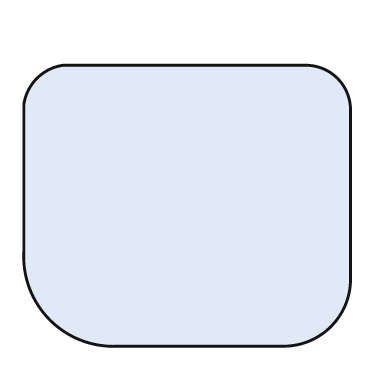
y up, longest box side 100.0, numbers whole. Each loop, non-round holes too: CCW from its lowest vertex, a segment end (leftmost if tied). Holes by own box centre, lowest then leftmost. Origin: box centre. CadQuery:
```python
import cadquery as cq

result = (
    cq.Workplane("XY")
    .moveTo(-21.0, -43.0)
    .lineTo(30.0, -43.0)
    .threePointArc((44.0, -37.0), (50.0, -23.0))
    .lineTo(50.0, 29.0)
    .threePointArc((46.0, 39.0), (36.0, 43.0))
    .lineTo(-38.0, 43.0)
    .threePointArc((-46.0, 39.0), (-50.0, 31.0))
    .lineTo(-50.0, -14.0)
    .threePointArc((-42.0, -35.0), (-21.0, -43.0))
    .close()
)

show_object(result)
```